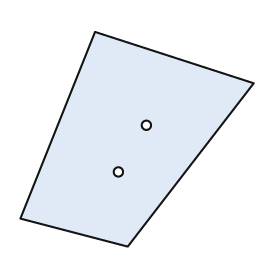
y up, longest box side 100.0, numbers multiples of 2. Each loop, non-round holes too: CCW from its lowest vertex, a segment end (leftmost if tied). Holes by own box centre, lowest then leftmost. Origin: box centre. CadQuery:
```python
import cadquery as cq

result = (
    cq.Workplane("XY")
    .moveTo(-4.0, -46.0)
    .lineTo(50.0, 24.0)
    .lineTo(-18.0, 46.0)
    .lineTo(-50.0, -34.0)
    .close()
    .moveTo(-8.0, -14.0)
    .circle(2.0)
    .moveTo(4.0, 6.0)
    .circle(2.0)
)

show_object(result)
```